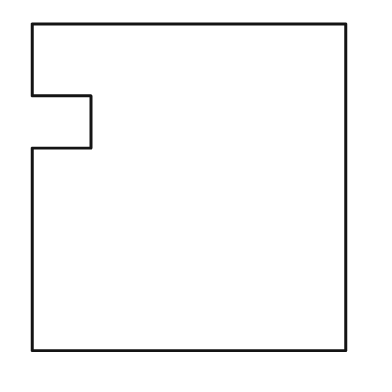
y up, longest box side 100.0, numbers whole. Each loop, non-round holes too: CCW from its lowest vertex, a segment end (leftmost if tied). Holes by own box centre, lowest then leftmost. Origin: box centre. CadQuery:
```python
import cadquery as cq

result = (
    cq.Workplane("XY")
    .moveTo(-48.0, -50.0)
    .lineTo(48.0, -50.0)
    .lineTo(48.0, 50.0)
    .lineTo(-48.0, 50.0)
    .lineTo(-48.0, 28.0)
    .lineTo(-30.0, 28.0)
    .lineTo(-30.0, 12.0)
    .lineTo(-48.0, 12.0)
    .close()
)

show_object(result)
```